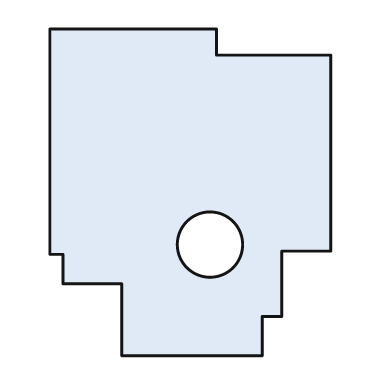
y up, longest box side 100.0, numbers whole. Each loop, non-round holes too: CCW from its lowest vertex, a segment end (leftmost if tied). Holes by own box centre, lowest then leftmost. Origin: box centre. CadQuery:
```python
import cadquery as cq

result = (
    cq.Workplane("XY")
    .moveTo(-21.0, -50.0)
    .lineTo(22.0, -50.0)
    .lineTo(22.0, -38.0)
    .lineTo(28.0, -38.0)
    .lineTo(28.0, -18.0)
    .lineTo(43.0, -18.0)
    .lineTo(43.0, 42.0)
    .lineTo(8.0, 42.0)
    .lineTo(8.0, 50.0)
    .lineTo(-43.0, 50.0)
    .lineTo(-43.0, -19.0)
    .lineTo(-39.0, -19.0)
    .lineTo(-39.0, -28.0)
    .lineTo(-21.0, -28.0)
    .close()
    .moveTo(6.0, -16.0)
    .circle(10.0)
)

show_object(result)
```